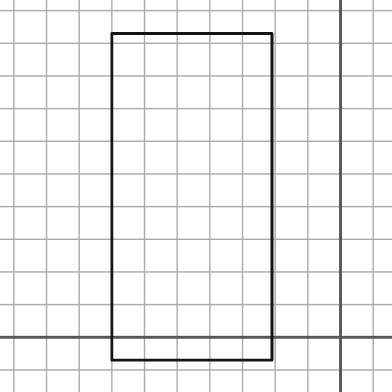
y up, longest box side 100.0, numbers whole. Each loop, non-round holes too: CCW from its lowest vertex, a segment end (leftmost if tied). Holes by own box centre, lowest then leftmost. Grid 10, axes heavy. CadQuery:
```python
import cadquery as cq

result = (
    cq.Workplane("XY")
    .moveTo(-70.0, -7.0)
    .lineTo(-21.0, -7.0)
    .lineTo(-21.0, 93.0)
    .lineTo(-70.0, 93.0)
    .close()
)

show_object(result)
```